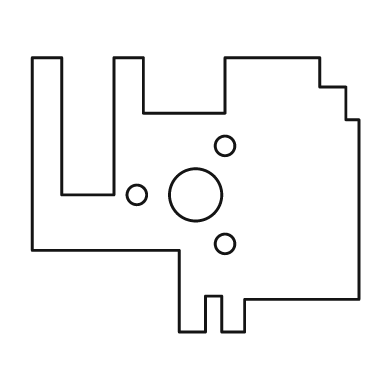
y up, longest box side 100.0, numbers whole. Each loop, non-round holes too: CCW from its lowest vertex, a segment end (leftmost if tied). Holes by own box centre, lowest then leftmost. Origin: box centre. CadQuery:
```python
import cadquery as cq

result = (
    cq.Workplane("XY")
    .moveTo(-5.0, -42.0)
    .lineTo(3.0, -42.0)
    .lineTo(3.0, -31.0)
    .lineTo(8.0, -31.0)
    .lineTo(8.0, -42.0)
    .lineTo(15.0, -42.0)
    .lineTo(15.0, -32.0)
    .lineTo(50.0, -32.0)
    .lineTo(50.0, 23.0)
    .lineTo(46.0, 23.0)
    .lineTo(46.0, 33.0)
    .lineTo(38.0, 33.0)
    .lineTo(38.0, 42.0)
    .lineTo(9.0, 42.0)
    .lineTo(9.0, 25.0)
    .lineTo(-16.0, 25.0)
    .lineTo(-16.0, 42.0)
    .lineTo(-25.0, 42.0)
    .lineTo(-25.0, 0.0)
    .lineTo(-41.0, 0.0)
    .lineTo(-41.0, 42.0)
    .lineTo(-50.0, 42.0)
    .lineTo(-50.0, -17.0)
    .lineTo(-5.0, -17.0)
    .close()
    .moveTo(9.0, -15.0)
    .circle(3.0)
    .moveTo(-18.0, 0.0)
    .circle(3.0)
    .moveTo(0.0, 0.0)
    .circle(8.0)
    .moveTo(9.0, 15.0)
    .circle(3.0)
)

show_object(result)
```